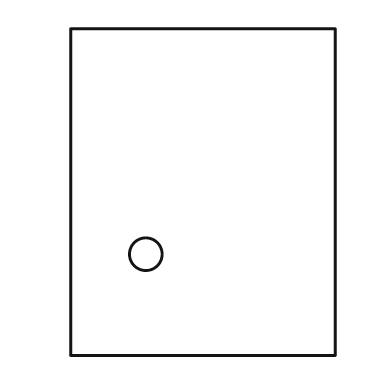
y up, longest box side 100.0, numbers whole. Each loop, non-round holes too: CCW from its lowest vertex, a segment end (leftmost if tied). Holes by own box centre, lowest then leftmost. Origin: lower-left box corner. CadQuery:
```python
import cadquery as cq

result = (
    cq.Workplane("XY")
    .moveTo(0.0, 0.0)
    .lineTo(81.0, 0.0)
    .lineTo(81.0, 100.0)
    .lineTo(0.0, 100.0)
    .close()
    .moveTo(23.0, 31.0)
    .circle(5.0)
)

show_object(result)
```